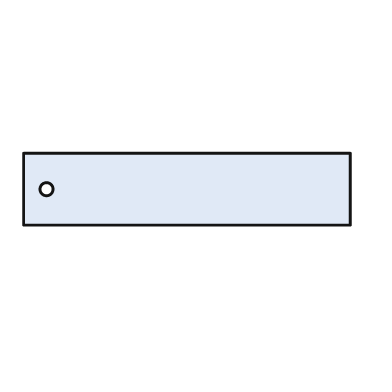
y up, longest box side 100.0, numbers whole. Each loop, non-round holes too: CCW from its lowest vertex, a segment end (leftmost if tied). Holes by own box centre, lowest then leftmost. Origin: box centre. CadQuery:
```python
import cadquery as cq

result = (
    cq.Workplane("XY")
    .moveTo(-50.0, -11.0)
    .lineTo(50.0, -11.0)
    .lineTo(50.0, 11.0)
    .lineTo(-50.0, 11.0)
    .close()
    .moveTo(-43.0, 0.0)
    .circle(2.0)
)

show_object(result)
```